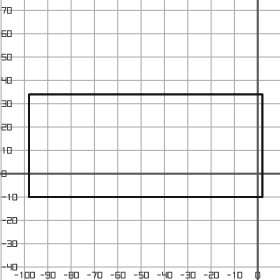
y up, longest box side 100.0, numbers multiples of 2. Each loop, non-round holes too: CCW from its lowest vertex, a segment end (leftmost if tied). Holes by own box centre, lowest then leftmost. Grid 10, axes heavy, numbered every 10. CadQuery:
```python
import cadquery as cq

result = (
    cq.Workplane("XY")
    .moveTo(-98.0, -10.0)
    .lineTo(2.0, -10.0)
    .lineTo(2.0, 34.0)
    .lineTo(-98.0, 34.0)
    .close()
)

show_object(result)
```